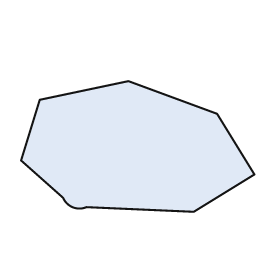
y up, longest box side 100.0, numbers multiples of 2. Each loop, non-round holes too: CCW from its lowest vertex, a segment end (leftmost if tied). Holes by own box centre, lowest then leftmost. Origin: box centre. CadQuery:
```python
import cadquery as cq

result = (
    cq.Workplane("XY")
    .moveTo(24.0, -28.0)
    .lineTo(50.0, -12.0)
    .lineTo(34.0, 14.0)
    .lineTo(-4.0, 28.0)
    .lineTo(-42.0, 20.0)
    .lineTo(-50.0, -6.0)
    .lineTo(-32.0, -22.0)
    .threePointArc((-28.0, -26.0), (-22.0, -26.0))
    .close()
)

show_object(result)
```